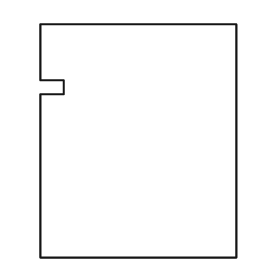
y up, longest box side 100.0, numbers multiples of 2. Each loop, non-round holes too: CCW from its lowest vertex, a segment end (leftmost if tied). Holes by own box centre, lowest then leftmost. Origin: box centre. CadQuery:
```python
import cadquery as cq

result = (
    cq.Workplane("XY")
    .moveTo(-42.0, -50.0)
    .lineTo(42.0, -50.0)
    .lineTo(42.0, 50.0)
    .lineTo(-42.0, 50.0)
    .lineTo(-42.0, 26.0)
    .lineTo(-32.0, 26.0)
    .lineTo(-32.0, 20.0)
    .lineTo(-42.0, 20.0)
    .close()
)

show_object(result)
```